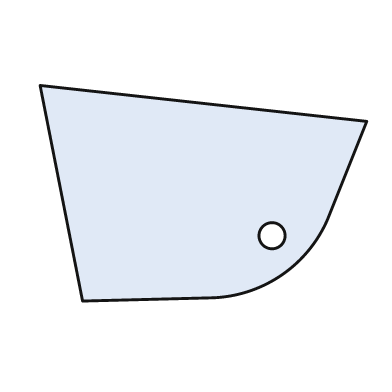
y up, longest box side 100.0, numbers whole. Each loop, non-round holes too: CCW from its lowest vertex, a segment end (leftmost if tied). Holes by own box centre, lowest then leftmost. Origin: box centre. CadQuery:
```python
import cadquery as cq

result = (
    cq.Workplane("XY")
    .moveTo(-37.0, -33.0)
    .lineTo(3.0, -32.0)
    .threePointArc((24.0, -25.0), (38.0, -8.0))
    .lineTo(50.0, 22.0)
    .lineTo(-50.0, 33.0)
    .close()
    .moveTo(21.0, -13.0)
    .circle(4.0)
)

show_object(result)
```